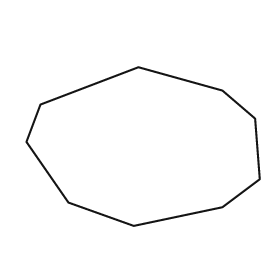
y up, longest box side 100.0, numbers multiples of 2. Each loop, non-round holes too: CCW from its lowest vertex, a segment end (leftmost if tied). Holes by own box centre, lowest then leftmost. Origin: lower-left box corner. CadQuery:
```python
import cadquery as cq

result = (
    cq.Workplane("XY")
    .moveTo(46.0, 0.0)
    .lineTo(84.0, 8.0)
    .lineTo(100.0, 20.0)
    .lineTo(98.0, 46.0)
    .lineTo(84.0, 58.0)
    .lineTo(48.0, 68.0)
    .lineTo(6.0, 52.0)
    .lineTo(0.0, 36.0)
    .lineTo(18.0, 10.0)
    .close()
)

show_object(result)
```